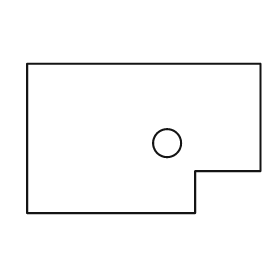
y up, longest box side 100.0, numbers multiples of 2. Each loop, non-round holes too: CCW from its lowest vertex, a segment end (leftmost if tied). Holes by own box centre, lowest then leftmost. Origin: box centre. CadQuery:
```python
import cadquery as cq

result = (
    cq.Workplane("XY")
    .moveTo(-50.0, -32.0)
    .lineTo(22.0, -32.0)
    .lineTo(22.0, -14.0)
    .lineTo(50.0, -14.0)
    .lineTo(50.0, 32.0)
    .lineTo(-50.0, 32.0)
    .close()
    .moveTo(10.0, -2.0)
    .circle(6.0)
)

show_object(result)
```